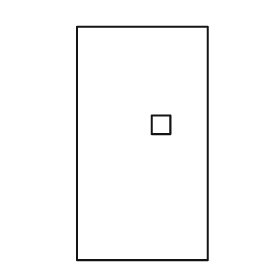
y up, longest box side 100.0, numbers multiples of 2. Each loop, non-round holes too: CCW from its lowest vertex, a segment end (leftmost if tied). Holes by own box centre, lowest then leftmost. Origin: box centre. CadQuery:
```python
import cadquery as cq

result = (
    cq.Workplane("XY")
    .moveTo(-28.0, -50.0)
    .lineTo(28.0, -50.0)
    .lineTo(28.0, 50.0)
    .lineTo(-28.0, 50.0)
    .close()
    .moveTo(4.0, 4.0)
    .lineTo(12.0, 4.0)
    .lineTo(12.0, 12.0)
    .lineTo(4.0, 12.0)
    .close()
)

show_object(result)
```